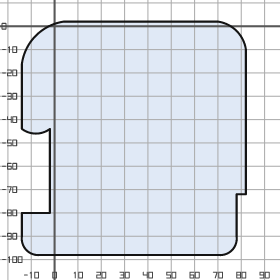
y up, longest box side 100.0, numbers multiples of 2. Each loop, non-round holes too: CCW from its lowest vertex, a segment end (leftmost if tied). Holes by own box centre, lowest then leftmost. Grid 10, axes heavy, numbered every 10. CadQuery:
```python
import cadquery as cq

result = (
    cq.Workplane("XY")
    .moveTo(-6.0, -98.0)
    .lineTo(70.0, -98.0)
    .threePointArc((76.0, -96.0), (78.0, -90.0))
    .lineTo(78.0, -72.0)
    .lineTo(82.0, -72.0)
    .lineTo(82.0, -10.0)
    .threePointArc((78.0, -2.0), (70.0, 2.0))
    .lineTo(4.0, 2.0)
    .threePointArc((-8.0, -4.0), (-14.0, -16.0))
    .lineTo(-14.0, -44.0)
    .threePointArc((-8.0, -46.0), (-2.0, -44.0))
    .lineTo(-2.0, -80.0)
    .lineTo(-14.0, -80.0)
    .lineTo(-14.0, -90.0)
    .threePointArc((-12.0, -96.0), (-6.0, -98.0))
    .close()
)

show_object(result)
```